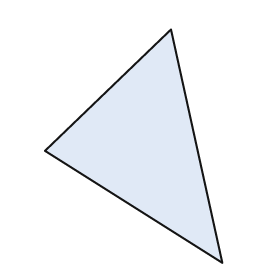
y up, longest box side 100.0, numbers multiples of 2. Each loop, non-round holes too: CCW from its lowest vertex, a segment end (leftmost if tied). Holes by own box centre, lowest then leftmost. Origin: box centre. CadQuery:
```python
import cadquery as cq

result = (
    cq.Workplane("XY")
    .moveTo(38.0, -50.0)
    .lineTo(16.0, 50.0)
    .lineTo(-38.0, -2.0)
    .close()
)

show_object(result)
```